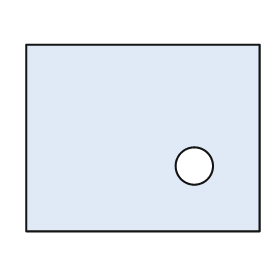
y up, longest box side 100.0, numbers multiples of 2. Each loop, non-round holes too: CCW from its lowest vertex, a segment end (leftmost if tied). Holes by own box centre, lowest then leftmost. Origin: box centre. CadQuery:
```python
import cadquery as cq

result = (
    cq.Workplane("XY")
    .moveTo(-50.0, -40.0)
    .lineTo(50.0, -40.0)
    .lineTo(50.0, 40.0)
    .lineTo(-50.0, 40.0)
    .close()
    .moveTo(22.0, -12.0)
    .circle(8.0)
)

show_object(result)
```